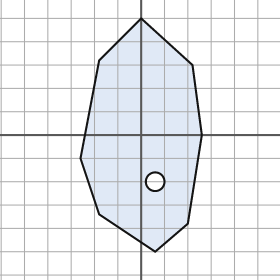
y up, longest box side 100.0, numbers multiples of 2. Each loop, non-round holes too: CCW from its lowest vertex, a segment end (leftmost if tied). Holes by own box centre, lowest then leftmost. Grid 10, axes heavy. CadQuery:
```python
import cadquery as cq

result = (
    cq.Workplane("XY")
    .moveTo(6.0, -50.0)
    .lineTo(20.0, -38.0)
    .lineTo(26.0, 0.0)
    .lineTo(22.0, 30.0)
    .lineTo(0.0, 50.0)
    .lineTo(-18.0, 32.0)
    .lineTo(-26.0, -10.0)
    .lineTo(-18.0, -34.0)
    .close()
    .moveTo(6.0, -20.0)
    .circle(4.0)
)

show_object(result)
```